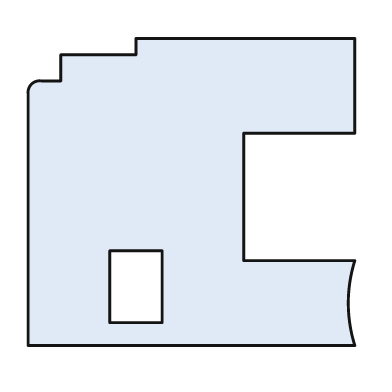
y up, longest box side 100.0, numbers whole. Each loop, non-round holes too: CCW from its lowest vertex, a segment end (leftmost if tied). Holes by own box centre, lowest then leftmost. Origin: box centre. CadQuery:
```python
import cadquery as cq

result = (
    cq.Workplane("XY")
    .moveTo(-50.0, -47.0)
    .lineTo(50.0, -47.0)
    .threePointArc((48.0, -34.0), (50.0, -21.0))
    .lineTo(16.0, -21.0)
    .lineTo(16.0, 18.0)
    .lineTo(50.0, 18.0)
    .lineTo(50.0, 47.0)
    .lineTo(-17.0, 47.0)
    .lineTo(-17.0, 42.0)
    .lineTo(-40.0, 42.0)
    .lineTo(-40.0, 34.0)
    .lineTo(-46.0, 34.0)
    .threePointArc((-49.0, 33.0), (-50.0, 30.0))
    .close()
    .moveTo(-25.0, -40.0)
    .lineTo(-9.0, -40.0)
    .lineTo(-9.0, -18.0)
    .lineTo(-25.0, -18.0)
    .close()
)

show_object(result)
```